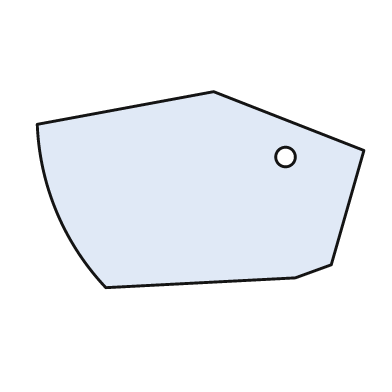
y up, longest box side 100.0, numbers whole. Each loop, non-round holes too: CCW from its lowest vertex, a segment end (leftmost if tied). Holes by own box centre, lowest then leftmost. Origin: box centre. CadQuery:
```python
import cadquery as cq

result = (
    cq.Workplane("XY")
    .moveTo(-29.0, -30.0)
    .lineTo(29.0, -27.0)
    .lineTo(40.0, -23.0)
    .lineTo(50.0, 12.0)
    .lineTo(4.0, 30.0)
    .lineTo(-50.0, 20.0)
    .threePointArc((-44.0, -7.0), (-29.0, -30.0))
    .close()
    .moveTo(26.0, 10.0)
    .circle(3.0)
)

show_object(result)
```